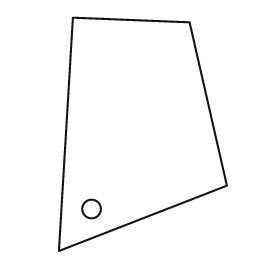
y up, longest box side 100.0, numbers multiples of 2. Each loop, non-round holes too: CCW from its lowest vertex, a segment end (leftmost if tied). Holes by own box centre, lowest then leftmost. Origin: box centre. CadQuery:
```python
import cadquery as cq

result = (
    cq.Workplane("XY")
    .moveTo(-36.0, -50.0)
    .lineTo(36.0, -22.0)
    .lineTo(20.0, 48.0)
    .lineTo(-30.0, 50.0)
    .close()
    .moveTo(-22.0, -32.0)
    .circle(4.0)
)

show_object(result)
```